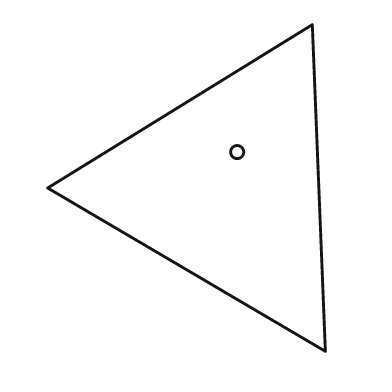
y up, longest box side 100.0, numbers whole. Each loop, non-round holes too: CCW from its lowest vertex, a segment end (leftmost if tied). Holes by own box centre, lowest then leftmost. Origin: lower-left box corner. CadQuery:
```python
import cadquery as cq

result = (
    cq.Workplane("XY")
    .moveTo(85.0, 0.0)
    .lineTo(81.0, 100.0)
    .lineTo(0.0, 50.0)
    .close()
    .moveTo(58.0, 61.0)
    .circle(2.0)
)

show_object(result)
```